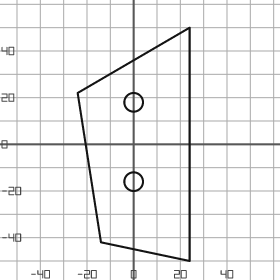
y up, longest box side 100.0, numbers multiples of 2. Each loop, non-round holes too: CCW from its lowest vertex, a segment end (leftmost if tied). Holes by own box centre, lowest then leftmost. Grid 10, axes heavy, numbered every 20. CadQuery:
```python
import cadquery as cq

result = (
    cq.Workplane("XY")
    .moveTo(24.0, -50.0)
    .lineTo(24.0, 50.0)
    .lineTo(-24.0, 22.0)
    .lineTo(-14.0, -42.0)
    .close()
    .moveTo(0.0, -16.0)
    .circle(4.0)
    .moveTo(0.0, 18.0)
    .circle(4.0)
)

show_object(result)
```